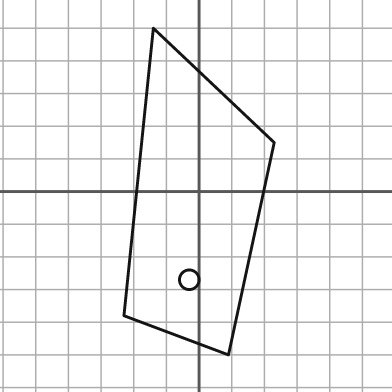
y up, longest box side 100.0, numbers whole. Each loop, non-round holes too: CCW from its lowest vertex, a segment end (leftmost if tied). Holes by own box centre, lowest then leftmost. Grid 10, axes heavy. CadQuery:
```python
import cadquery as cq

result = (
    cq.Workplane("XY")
    .moveTo(9.0, -50.0)
    .lineTo(23.0, 15.0)
    .lineTo(-14.0, 50.0)
    .lineTo(-23.0, -38.0)
    .close()
    .moveTo(-3.0, -27.0)
    .circle(3.0)
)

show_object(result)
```